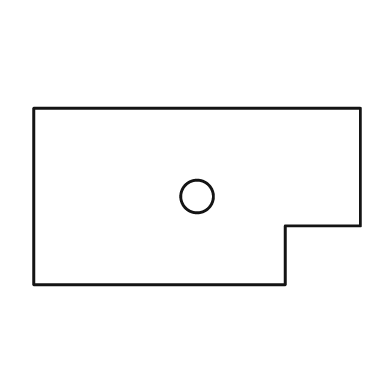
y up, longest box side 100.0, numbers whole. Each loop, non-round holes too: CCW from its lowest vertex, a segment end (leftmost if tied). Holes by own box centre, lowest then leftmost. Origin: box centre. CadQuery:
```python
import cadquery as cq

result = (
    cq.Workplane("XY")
    .moveTo(-50.0, -27.0)
    .lineTo(27.0, -27.0)
    .lineTo(27.0, -9.0)
    .lineTo(50.0, -9.0)
    .lineTo(50.0, 27.0)
    .lineTo(-50.0, 27.0)
    .close()
    .moveTo(0.0, 0.0)
    .circle(5.0)
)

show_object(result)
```